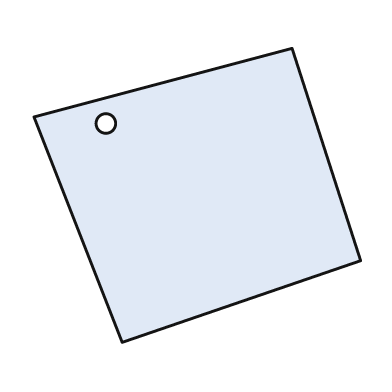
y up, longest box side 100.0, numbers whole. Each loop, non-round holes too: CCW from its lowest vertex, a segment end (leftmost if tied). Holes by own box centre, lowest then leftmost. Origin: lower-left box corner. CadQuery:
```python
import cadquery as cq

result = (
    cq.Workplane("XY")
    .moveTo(27.0, 0.0)
    .lineTo(100.0, 25.0)
    .lineTo(79.0, 90.0)
    .lineTo(0.0, 69.0)
    .close()
    .moveTo(22.0, 67.0)
    .circle(3.0)
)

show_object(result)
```